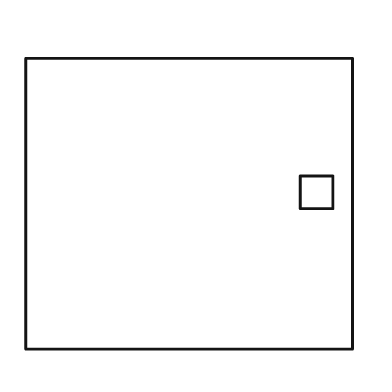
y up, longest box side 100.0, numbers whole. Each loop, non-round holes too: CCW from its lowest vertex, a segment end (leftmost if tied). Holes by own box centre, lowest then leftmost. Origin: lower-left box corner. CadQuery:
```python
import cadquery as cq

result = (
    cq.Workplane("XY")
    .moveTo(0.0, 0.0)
    .lineTo(100.0, 0.0)
    .lineTo(100.0, 89.0)
    .lineTo(0.0, 89.0)
    .close()
    .moveTo(84.0, 43.0)
    .lineTo(94.0, 43.0)
    .lineTo(94.0, 53.0)
    .lineTo(84.0, 53.0)
    .close()
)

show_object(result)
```